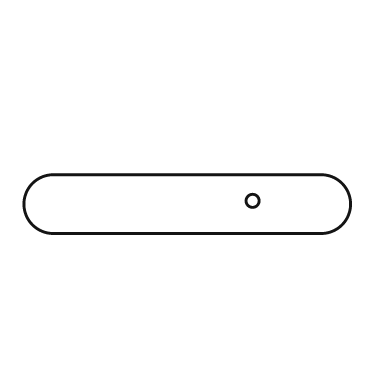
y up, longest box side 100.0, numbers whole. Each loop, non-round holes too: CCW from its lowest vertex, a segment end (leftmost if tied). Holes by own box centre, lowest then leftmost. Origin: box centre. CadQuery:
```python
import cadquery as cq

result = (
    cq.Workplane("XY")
    .moveTo(-41.0, -9.0)
    .lineTo(41.0, -9.0)
    .threePointArc((50.0, 0.0), (41.0, 9.0))
    .lineTo(-41.0, 9.0)
    .threePointArc((-50.0, 0.0), (-41.0, -9.0))
    .close()
    .moveTo(20.0, 1.0)
    .circle(2.0)
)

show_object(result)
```